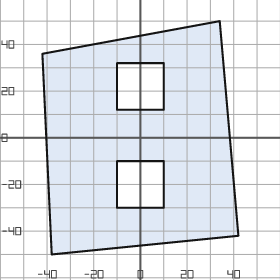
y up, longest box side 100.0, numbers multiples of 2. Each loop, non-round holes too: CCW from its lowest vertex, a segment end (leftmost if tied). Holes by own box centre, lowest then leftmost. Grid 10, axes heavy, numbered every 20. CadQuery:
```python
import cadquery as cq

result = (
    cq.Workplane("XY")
    .moveTo(-38.0, -50.0)
    .lineTo(42.0, -42.0)
    .lineTo(34.0, 50.0)
    .lineTo(-42.0, 36.0)
    .close()
    .moveTo(-10.0, -30.0)
    .lineTo(10.0, -30.0)
    .lineTo(10.0, -10.0)
    .lineTo(-10.0, -10.0)
    .close()
    .moveTo(-10.0, 12.0)
    .lineTo(10.0, 12.0)
    .lineTo(10.0, 32.0)
    .lineTo(-10.0, 32.0)
    .close()
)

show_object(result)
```